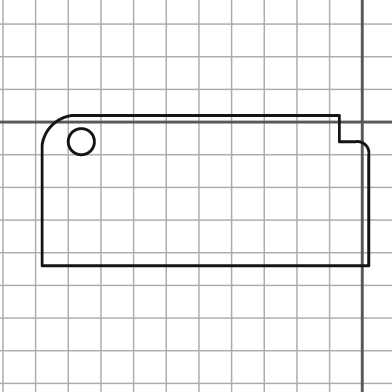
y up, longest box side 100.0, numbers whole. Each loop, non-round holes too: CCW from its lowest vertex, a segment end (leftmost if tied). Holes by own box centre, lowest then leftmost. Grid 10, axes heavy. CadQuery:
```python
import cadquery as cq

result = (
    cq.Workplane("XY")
    .moveTo(-98.0, -44.0)
    .lineTo(2.0, -44.0)
    .lineTo(2.0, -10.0)
    .threePointArc((1.0, -7.0), (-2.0, -6.0))
    .lineTo(-7.0, -6.0)
    .lineTo(-7.0, 2.0)
    .lineTo(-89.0, 2.0)
    .threePointArc((-95.0, -1.0), (-98.0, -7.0))
    .close()
    .moveTo(-86.0, -6.0)
    .circle(4.0)
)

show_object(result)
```